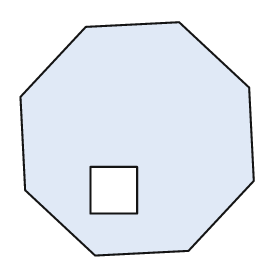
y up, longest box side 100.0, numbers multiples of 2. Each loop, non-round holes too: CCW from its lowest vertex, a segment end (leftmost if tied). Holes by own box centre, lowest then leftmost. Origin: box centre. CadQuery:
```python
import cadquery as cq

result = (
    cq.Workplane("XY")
    .moveTo(-18.0, -50.0)
    .lineTo(22.0, -48.0)
    .lineTo(50.0, -18.0)
    .lineTo(48.0, 22.0)
    .lineTo(18.0, 50.0)
    .lineTo(-22.0, 48.0)
    .lineTo(-50.0, 18.0)
    .lineTo(-48.0, -22.0)
    .close()
    .moveTo(-20.0, -32.0)
    .lineTo(0.0, -32.0)
    .lineTo(0.0, -12.0)
    .lineTo(-20.0, -12.0)
    .close()
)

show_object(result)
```